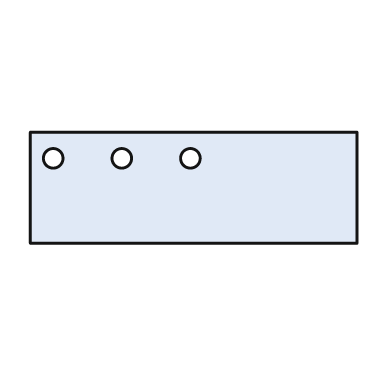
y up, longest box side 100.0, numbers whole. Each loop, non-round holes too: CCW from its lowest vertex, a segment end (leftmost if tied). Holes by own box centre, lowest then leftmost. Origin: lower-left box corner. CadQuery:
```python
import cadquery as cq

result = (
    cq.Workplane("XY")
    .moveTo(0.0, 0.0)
    .lineTo(100.0, 0.0)
    .lineTo(100.0, 34.0)
    .lineTo(0.0, 34.0)
    .close()
    .moveTo(7.0, 26.0)
    .circle(3.0)
    .moveTo(28.0, 26.0)
    .circle(3.0)
    .moveTo(49.0, 26.0)
    .circle(3.0)
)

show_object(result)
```